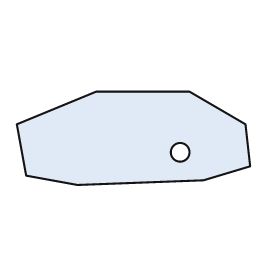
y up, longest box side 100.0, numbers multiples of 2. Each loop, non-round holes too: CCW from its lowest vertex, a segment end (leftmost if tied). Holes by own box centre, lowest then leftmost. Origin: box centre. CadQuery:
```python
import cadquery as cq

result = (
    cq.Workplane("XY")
    .moveTo(-24.0, -20.0)
    .lineTo(30.0, -18.0)
    .lineTo(50.0, -12.0)
    .lineTo(48.0, 6.0)
    .lineTo(24.0, 20.0)
    .lineTo(-16.0, 20.0)
    .lineTo(-50.0, 6.0)
    .lineTo(-46.0, -16.0)
    .close()
    .moveTo(20.0, -6.0)
    .circle(4.0)
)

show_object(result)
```